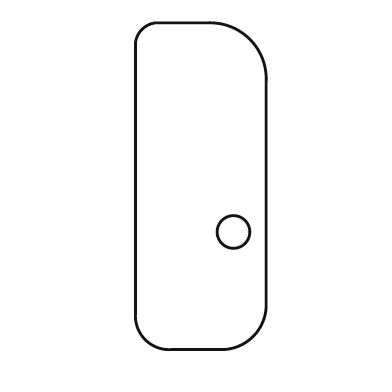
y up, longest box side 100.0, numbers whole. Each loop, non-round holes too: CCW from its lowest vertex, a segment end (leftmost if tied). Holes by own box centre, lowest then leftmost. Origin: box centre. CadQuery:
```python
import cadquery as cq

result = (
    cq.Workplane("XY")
    .moveTo(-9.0, -50.0)
    .lineTo(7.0, -50.0)
    .threePointArc((16.0, -46.0), (20.0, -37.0))
    .lineTo(20.0, 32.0)
    .threePointArc((15.0, 45.0), (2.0, 50.0))
    .lineTo(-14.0, 50.0)
    .threePointArc((-18.0, 48.0), (-20.0, 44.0))
    .lineTo(-20.0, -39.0)
    .threePointArc((-17.0, -47.0), (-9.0, -50.0))
    .close()
    .moveTo(10.0, -14.0)
    .circle(5.0)
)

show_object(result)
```